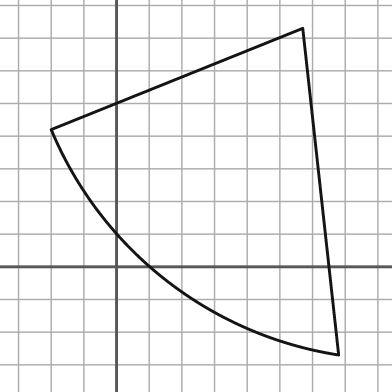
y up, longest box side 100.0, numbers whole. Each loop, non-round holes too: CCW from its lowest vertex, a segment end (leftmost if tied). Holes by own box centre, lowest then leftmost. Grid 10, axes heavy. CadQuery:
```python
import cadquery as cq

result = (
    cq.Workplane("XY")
    .moveTo(68.0, -27.0)
    .lineTo(57.0, 73.0)
    .lineTo(-20.0, 42.0)
    .threePointArc((15.0, -4.0), (68.0, -27.0))
    .close()
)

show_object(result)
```